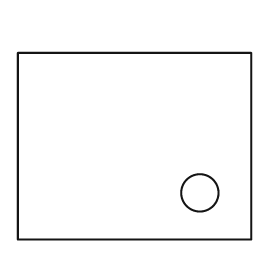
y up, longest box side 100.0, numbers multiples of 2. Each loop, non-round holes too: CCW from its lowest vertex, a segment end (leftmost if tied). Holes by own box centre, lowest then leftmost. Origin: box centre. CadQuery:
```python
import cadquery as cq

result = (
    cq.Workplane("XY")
    .moveTo(-50.0, -40.0)
    .lineTo(50.0, -40.0)
    .lineTo(50.0, 40.0)
    .lineTo(-50.0, 40.0)
    .close()
    .moveTo(28.0, -20.0)
    .circle(8.0)
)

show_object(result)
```